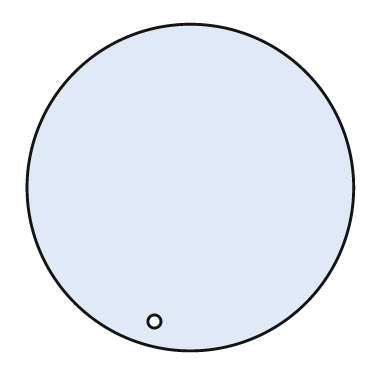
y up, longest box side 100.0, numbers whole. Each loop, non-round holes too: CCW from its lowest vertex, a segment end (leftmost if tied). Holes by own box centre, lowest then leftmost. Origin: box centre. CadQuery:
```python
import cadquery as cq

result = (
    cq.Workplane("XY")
    .moveTo(0.0, 0.0)
    .circle(50.0)
    .moveTo(-11.0, -41.0)
    .circle(2.0)
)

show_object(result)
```